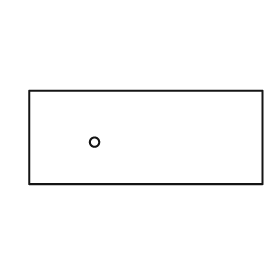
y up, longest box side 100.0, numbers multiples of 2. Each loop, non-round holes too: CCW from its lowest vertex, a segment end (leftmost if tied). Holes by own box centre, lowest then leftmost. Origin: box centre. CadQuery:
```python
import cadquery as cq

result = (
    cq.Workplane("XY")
    .moveTo(-50.0, -20.0)
    .lineTo(50.0, -20.0)
    .lineTo(50.0, 20.0)
    .lineTo(-50.0, 20.0)
    .close()
    .moveTo(-22.0, -2.0)
    .circle(2.0)
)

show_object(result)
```